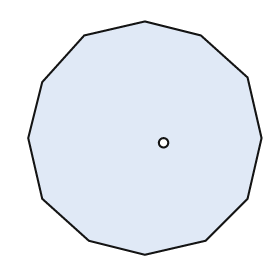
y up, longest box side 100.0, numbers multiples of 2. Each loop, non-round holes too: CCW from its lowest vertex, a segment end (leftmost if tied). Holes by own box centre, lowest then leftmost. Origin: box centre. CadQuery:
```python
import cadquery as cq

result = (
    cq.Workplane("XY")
    .moveTo(0.0, -50.0)
    .lineTo(26.0, -44.0)
    .lineTo(44.0, -26.0)
    .lineTo(50.0, 0.0)
    .lineTo(44.0, 26.0)
    .lineTo(24.0, 44.0)
    .lineTo(0.0, 50.0)
    .lineTo(-26.0, 44.0)
    .lineTo(-44.0, 24.0)
    .lineTo(-50.0, 0.0)
    .lineTo(-44.0, -26.0)
    .lineTo(-24.0, -44.0)
    .close()
    .moveTo(8.0, -2.0)
    .circle(2.0)
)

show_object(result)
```